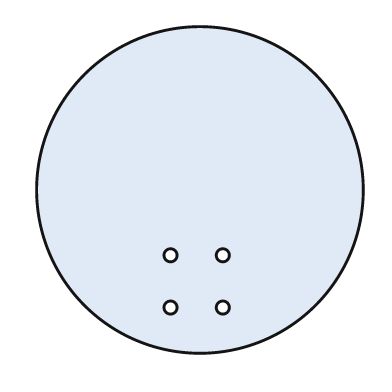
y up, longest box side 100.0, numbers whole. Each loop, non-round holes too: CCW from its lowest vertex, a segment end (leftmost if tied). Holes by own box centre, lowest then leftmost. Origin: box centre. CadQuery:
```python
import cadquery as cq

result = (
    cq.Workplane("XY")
    .moveTo(0.0, 0.0)
    .circle(50.0)
    .moveTo(-9.0, -36.0)
    .circle(2.0)
    .moveTo(7.0, -36.0)
    .circle(2.0)
    .moveTo(-9.0, -20.0)
    .circle(2.0)
    .moveTo(7.0, -20.0)
    .circle(2.0)
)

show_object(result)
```